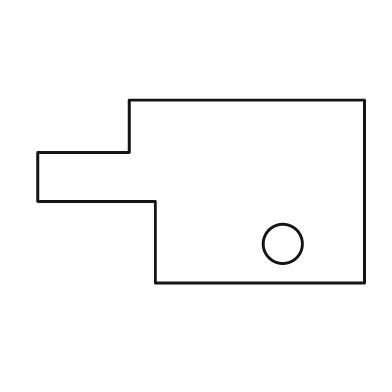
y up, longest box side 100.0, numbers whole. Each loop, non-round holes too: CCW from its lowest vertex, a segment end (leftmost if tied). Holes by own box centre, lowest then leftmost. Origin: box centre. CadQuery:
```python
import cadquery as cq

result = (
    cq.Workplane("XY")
    .moveTo(-14.0, -28.0)
    .lineTo(50.0, -28.0)
    .lineTo(50.0, 28.0)
    .lineTo(-22.0, 28.0)
    .lineTo(-22.0, 12.0)
    .lineTo(-50.0, 12.0)
    .lineTo(-50.0, -3.0)
    .lineTo(-14.0, -3.0)
    .close()
    .moveTo(25.0, -16.0)
    .circle(6.0)
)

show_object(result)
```